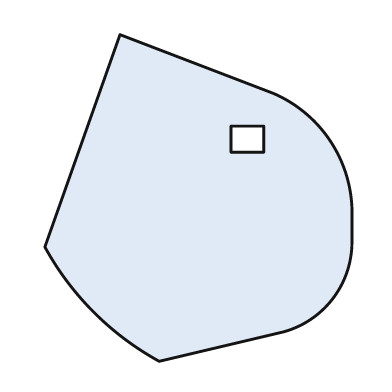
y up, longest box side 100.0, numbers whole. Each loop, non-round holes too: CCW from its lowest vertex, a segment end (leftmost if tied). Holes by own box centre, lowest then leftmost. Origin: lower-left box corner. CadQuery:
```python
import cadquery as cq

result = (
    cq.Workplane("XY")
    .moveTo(35.0, 0.0)
    .lineTo(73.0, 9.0)
    .threePointArc((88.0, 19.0), (94.0, 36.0))
    .lineTo(94.0, 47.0)
    .threePointArc((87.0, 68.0), (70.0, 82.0))
    .lineTo(23.0, 100.0)
    .lineTo(0.0, 35.0)
    .threePointArc((15.0, 15.0), (35.0, 0.0))
    .close()
    .moveTo(57.0, 64.0)
    .lineTo(67.0, 64.0)
    .lineTo(67.0, 72.0)
    .lineTo(57.0, 72.0)
    .close()
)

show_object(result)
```